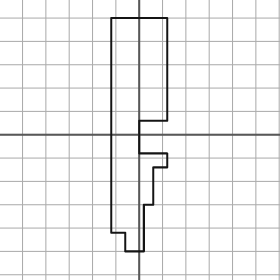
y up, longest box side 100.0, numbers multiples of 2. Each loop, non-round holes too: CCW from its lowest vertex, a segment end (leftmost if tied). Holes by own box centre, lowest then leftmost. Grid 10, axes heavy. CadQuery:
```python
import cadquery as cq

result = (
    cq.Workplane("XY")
    .moveTo(-6.0, -50.0)
    .lineTo(2.0, -50.0)
    .lineTo(2.0, -30.0)
    .lineTo(6.0, -30.0)
    .lineTo(6.0, -14.0)
    .lineTo(12.0, -14.0)
    .lineTo(12.0, -8.0)
    .lineTo(0.0, -8.0)
    .lineTo(0.0, 6.0)
    .lineTo(12.0, 6.0)
    .lineTo(12.0, 50.0)
    .lineTo(-12.0, 50.0)
    .lineTo(-12.0, -42.0)
    .lineTo(-6.0, -42.0)
    .close()
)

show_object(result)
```